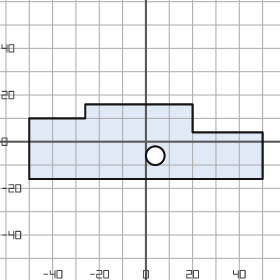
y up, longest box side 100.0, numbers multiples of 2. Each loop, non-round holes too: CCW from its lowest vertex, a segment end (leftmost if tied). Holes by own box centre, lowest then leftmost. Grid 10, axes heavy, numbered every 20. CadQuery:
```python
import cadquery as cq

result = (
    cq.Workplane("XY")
    .moveTo(-50.0, -16.0)
    .lineTo(50.0, -16.0)
    .lineTo(50.0, 4.0)
    .lineTo(20.0, 4.0)
    .lineTo(20.0, 16.0)
    .lineTo(-26.0, 16.0)
    .lineTo(-26.0, 10.0)
    .lineTo(-50.0, 10.0)
    .close()
    .moveTo(4.0, -6.0)
    .circle(4.0)
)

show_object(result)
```